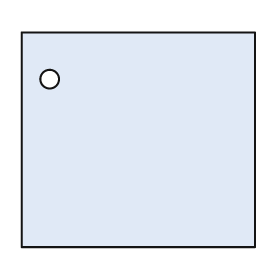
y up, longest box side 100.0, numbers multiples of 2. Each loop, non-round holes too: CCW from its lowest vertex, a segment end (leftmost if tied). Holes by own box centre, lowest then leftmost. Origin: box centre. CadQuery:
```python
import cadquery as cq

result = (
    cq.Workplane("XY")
    .moveTo(-50.0, -46.0)
    .lineTo(50.0, -46.0)
    .lineTo(50.0, 46.0)
    .lineTo(-50.0, 46.0)
    .close()
    .moveTo(-38.0, 26.0)
    .circle(4.0)
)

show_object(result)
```